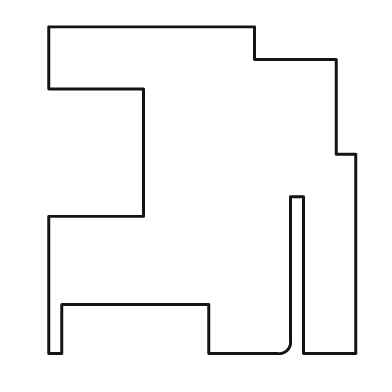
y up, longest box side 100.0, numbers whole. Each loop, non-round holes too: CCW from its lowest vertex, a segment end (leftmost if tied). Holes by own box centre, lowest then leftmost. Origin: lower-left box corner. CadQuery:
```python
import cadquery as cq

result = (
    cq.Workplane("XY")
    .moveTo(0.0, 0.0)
    .lineTo(4.0, 0.0)
    .lineTo(4.0, 15.0)
    .lineTo(49.0, 15.0)
    .lineTo(49.0, 0.0)
    .lineTo(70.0, 0.0)
    .threePointArc((73.0, 1.0), (74.0, 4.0))
    .lineTo(74.0, 48.0)
    .lineTo(78.0, 48.0)
    .lineTo(78.0, 0.0)
    .lineTo(94.0, 0.0)
    .lineTo(94.0, 61.0)
    .lineTo(88.0, 61.0)
    .lineTo(88.0, 90.0)
    .lineTo(63.0, 90.0)
    .lineTo(63.0, 100.0)
    .lineTo(0.0, 100.0)
    .lineTo(0.0, 81.0)
    .lineTo(29.0, 81.0)
    .lineTo(29.0, 42.0)
    .lineTo(0.0, 42.0)
    .close()
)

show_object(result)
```